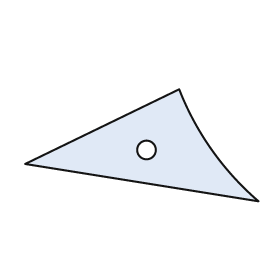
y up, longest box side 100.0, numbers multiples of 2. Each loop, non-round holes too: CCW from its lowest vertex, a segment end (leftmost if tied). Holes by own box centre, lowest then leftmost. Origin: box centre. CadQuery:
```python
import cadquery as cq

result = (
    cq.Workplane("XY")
    .moveTo(50.0, -24.0)
    .threePointArc((30.0, -2.0), (16.0, 24.0))
    .lineTo(-50.0, -8.0)
    .close()
    .moveTo(2.0, -2.0)
    .circle(4.0)
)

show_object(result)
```